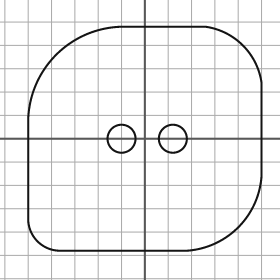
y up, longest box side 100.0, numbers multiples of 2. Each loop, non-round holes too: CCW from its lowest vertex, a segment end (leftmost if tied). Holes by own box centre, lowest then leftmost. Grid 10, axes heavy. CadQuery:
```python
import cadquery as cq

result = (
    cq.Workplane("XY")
    .moveTo(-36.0, -48.0)
    .lineTo(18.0, -48.0)
    .threePointArc((40.0, -38.0), (50.0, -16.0))
    .lineTo(50.0, 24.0)
    .threePointArc((42.0, 40.0), (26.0, 48.0))
    .lineTo(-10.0, 48.0)
    .threePointArc((-38.0, 36.0), (-50.0, 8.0))
    .lineTo(-50.0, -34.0)
    .threePointArc((-46.0, -44.0), (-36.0, -48.0))
    .close()
    .moveTo(-10.0, 0.0)
    .circle(6.0)
    .moveTo(12.0, 0.0)
    .circle(6.0)
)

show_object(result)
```